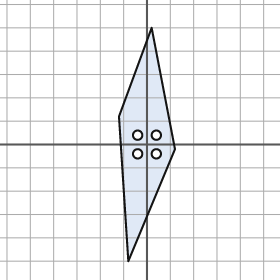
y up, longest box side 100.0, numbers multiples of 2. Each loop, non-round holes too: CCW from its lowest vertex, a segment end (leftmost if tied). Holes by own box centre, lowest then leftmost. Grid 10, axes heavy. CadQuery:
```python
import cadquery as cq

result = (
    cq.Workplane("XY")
    .moveTo(-8.0, -50.0)
    .lineTo(12.0, -2.0)
    .lineTo(2.0, 50.0)
    .lineTo(-12.0, 12.0)
    .close()
    .moveTo(-4.0, -4.0)
    .circle(2.0)
    .moveTo(4.0, -4.0)
    .circle(2.0)
    .moveTo(-4.0, 4.0)
    .circle(2.0)
    .moveTo(4.0, 4.0)
    .circle(2.0)
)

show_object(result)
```